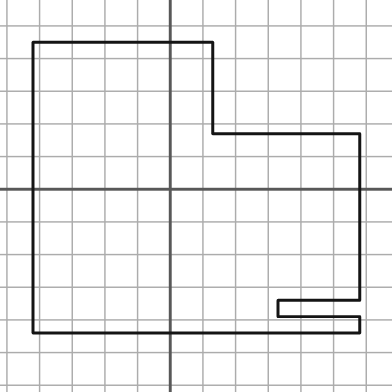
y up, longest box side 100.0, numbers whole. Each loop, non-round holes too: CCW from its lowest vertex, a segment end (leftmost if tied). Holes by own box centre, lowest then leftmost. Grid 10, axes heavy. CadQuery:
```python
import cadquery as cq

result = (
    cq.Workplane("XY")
    .moveTo(-42.0, -44.0)
    .lineTo(58.0, -44.0)
    .lineTo(58.0, -39.0)
    .lineTo(33.0, -39.0)
    .lineTo(33.0, -34.0)
    .lineTo(58.0, -34.0)
    .lineTo(58.0, 17.0)
    .lineTo(13.0, 17.0)
    .lineTo(13.0, 45.0)
    .lineTo(-42.0, 45.0)
    .close()
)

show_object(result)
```